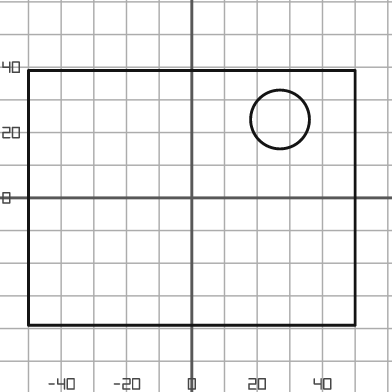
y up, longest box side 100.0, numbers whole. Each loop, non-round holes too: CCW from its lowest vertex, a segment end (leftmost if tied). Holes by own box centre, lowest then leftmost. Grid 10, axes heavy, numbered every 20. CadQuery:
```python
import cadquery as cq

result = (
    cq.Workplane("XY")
    .moveTo(-50.0, -39.0)
    .lineTo(50.0, -39.0)
    .lineTo(50.0, 39.0)
    .lineTo(-50.0, 39.0)
    .close()
    .moveTo(27.0, 24.0)
    .circle(9.0)
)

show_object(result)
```